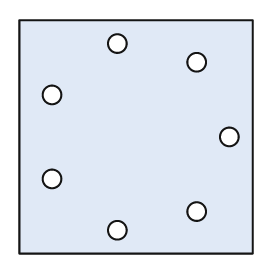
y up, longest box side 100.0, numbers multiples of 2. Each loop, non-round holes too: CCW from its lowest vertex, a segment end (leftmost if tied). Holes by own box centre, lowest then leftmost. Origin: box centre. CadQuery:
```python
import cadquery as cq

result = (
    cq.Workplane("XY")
    .moveTo(-50.0, -50.0)
    .lineTo(50.0, -50.0)
    .lineTo(50.0, 50.0)
    .lineTo(-50.0, 50.0)
    .close()
    .moveTo(-8.0, -40.0)
    .circle(4.0)
    .moveTo(26.0, -32.0)
    .circle(4.0)
    .moveTo(-36.0, -18.0)
    .circle(4.0)
    .moveTo(40.0, 0.0)
    .circle(4.0)
    .moveTo(-36.0, 18.0)
    .circle(4.0)
    .moveTo(26.0, 32.0)
    .circle(4.0)
    .moveTo(-8.0, 40.0)
    .circle(4.0)
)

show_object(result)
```